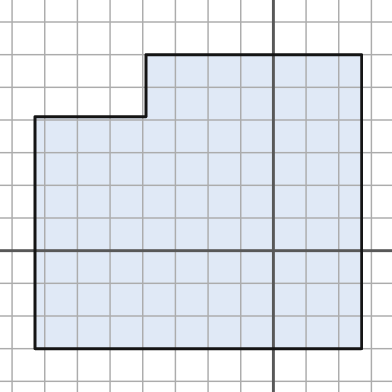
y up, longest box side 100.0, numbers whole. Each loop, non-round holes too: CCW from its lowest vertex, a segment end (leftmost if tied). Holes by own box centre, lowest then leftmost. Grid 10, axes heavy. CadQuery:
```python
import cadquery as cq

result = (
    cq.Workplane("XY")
    .moveTo(-73.0, -30.0)
    .lineTo(27.0, -30.0)
    .lineTo(27.0, 60.0)
    .lineTo(-39.0, 60.0)
    .lineTo(-39.0, 41.0)
    .lineTo(-73.0, 41.0)
    .close()
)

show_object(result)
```